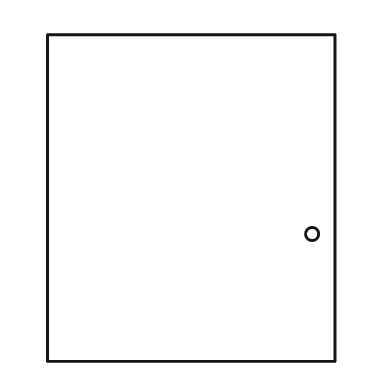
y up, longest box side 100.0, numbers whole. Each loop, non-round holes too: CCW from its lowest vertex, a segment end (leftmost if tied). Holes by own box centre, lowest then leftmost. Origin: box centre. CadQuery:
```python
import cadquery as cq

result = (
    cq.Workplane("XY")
    .moveTo(-44.0, -50.0)
    .lineTo(44.0, -50.0)
    .lineTo(44.0, 50.0)
    .lineTo(-44.0, 50.0)
    .close()
    .moveTo(37.0, -11.0)
    .circle(2.0)
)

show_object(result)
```